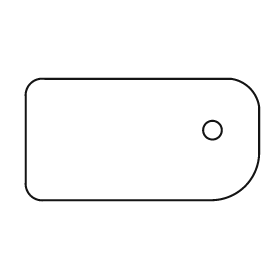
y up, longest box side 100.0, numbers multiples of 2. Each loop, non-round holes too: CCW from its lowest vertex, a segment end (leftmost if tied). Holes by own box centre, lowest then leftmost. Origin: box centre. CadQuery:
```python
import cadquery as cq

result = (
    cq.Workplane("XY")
    .moveTo(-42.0, -26.0)
    .lineTo(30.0, -26.0)
    .threePointArc((44.0, -20.0), (50.0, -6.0))
    .lineTo(50.0, 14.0)
    .threePointArc((46.0, 22.0), (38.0, 26.0))
    .lineTo(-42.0, 26.0)
    .threePointArc((-48.0, 24.0), (-50.0, 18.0))
    .lineTo(-50.0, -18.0)
    .threePointArc((-48.0, -24.0), (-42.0, -26.0))
    .close()
    .moveTo(30.0, 4.0)
    .circle(4.0)
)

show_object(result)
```